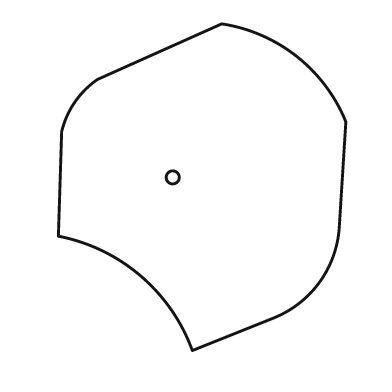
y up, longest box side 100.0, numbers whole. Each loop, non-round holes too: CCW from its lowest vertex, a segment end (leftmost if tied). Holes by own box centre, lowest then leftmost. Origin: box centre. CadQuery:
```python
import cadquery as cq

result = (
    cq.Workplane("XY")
    .moveTo(-3.0, -50.0)
    .lineTo(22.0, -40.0)
    .threePointArc((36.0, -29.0), (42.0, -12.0))
    .lineTo(44.0, 20.0)
    .threePointArc((29.0, 40.0), (6.0, 50.0))
    .lineTo(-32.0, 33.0)
    .threePointArc((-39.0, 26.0), (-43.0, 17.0))
    .lineTo(-44.0, -15.0)
    .threePointArc((-19.0, -27.0), (-3.0, -50.0))
    .close()
    .moveTo(-9.0, 3.0)
    .circle(2.0)
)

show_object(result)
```